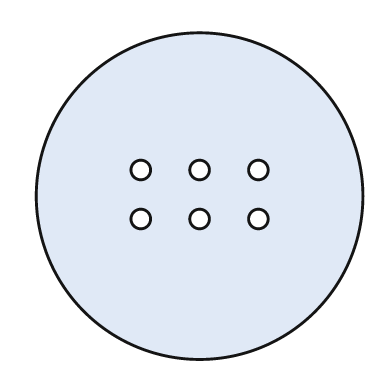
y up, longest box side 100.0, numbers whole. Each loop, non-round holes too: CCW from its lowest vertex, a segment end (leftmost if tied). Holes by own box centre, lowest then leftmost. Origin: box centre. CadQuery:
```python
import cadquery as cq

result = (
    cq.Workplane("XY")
    .moveTo(0.0, 0.0)
    .circle(50.0)
    .moveTo(-18.0, -7.0)
    .circle(3.0)
    .moveTo(0.0, -7.0)
    .circle(3.0)
    .moveTo(18.0, -7.0)
    .circle(3.0)
    .moveTo(-18.0, 8.0)
    .circle(3.0)
    .moveTo(0.0, 8.0)
    .circle(3.0)
    .moveTo(18.0, 8.0)
    .circle(3.0)
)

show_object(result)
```